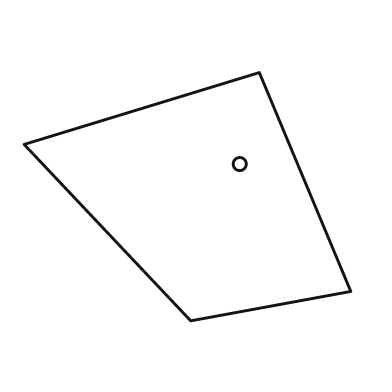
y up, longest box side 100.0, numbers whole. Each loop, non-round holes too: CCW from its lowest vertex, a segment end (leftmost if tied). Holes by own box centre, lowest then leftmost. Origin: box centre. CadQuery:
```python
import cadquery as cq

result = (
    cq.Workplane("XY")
    .moveTo(1.0, -38.0)
    .lineTo(50.0, -29.0)
    .lineTo(22.0, 38.0)
    .lineTo(-50.0, 16.0)
    .close()
    .moveTo(16.0, 10.0)
    .circle(2.0)
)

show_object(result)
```